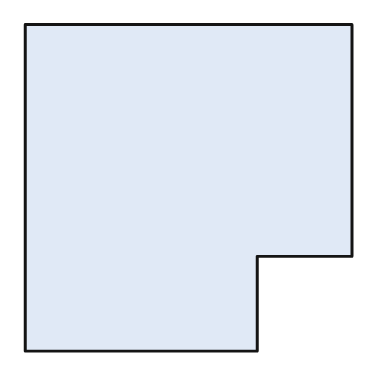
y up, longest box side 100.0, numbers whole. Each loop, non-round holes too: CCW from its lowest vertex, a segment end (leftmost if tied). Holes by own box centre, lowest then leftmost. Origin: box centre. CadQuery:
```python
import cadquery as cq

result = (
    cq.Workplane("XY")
    .moveTo(-50.0, -50.0)
    .lineTo(21.0, -50.0)
    .lineTo(21.0, -21.0)
    .lineTo(50.0, -21.0)
    .lineTo(50.0, 50.0)
    .lineTo(-50.0, 50.0)
    .close()
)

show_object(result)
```